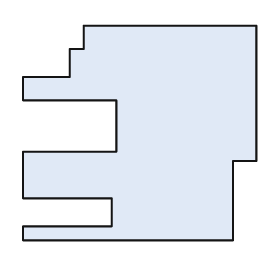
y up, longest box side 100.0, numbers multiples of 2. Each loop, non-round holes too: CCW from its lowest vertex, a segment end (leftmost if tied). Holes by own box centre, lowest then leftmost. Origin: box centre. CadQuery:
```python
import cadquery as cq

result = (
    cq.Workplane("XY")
    .moveTo(-50.0, -46.0)
    .lineTo(40.0, -46.0)
    .lineTo(40.0, -12.0)
    .lineTo(50.0, -12.0)
    .lineTo(50.0, 46.0)
    .lineTo(-24.0, 46.0)
    .lineTo(-24.0, 36.0)
    .lineTo(-30.0, 36.0)
    .lineTo(-30.0, 24.0)
    .lineTo(-50.0, 24.0)
    .lineTo(-50.0, 14.0)
    .lineTo(-10.0, 14.0)
    .lineTo(-10.0, -8.0)
    .lineTo(-50.0, -8.0)
    .lineTo(-50.0, -28.0)
    .lineTo(-12.0, -28.0)
    .lineTo(-12.0, -40.0)
    .lineTo(-50.0, -40.0)
    .close()
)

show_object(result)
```